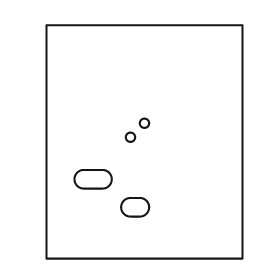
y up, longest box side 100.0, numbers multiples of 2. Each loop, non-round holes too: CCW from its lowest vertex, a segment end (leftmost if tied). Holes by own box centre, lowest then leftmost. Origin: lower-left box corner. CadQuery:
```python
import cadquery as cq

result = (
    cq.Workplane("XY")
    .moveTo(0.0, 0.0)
    .lineTo(84.0, 0.0)
    .lineTo(84.0, 100.0)
    .lineTo(0.0, 100.0)
    .close()
    .moveTo(36.0, 18.0)
    .lineTo(40.0, 18.0)
    .threePointArc((44.0, 22.0), (40.0, 26.0))
    .lineTo(36.0, 26.0)
    .threePointArc((32.0, 22.0), (36.0, 18.0))
    .close()
    .moveTo(16.0, 30.0)
    .lineTo(24.0, 30.0)
    .threePointArc((28.0, 34.0), (24.0, 38.0))
    .lineTo(16.0, 38.0)
    .threePointArc((12.0, 34.0), (16.0, 30.0))
    .close()
    .moveTo(36.0, 52.0)
    .circle(2.0)
    .moveTo(42.0, 58.0)
    .circle(2.0)
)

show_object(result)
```